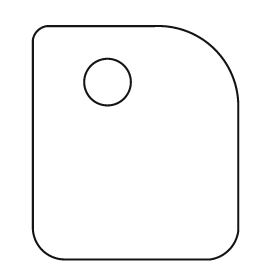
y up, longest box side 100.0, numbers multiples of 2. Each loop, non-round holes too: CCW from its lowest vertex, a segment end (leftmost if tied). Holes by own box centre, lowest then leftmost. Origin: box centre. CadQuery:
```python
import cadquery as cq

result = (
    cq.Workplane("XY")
    .moveTo(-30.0, -50.0)
    .lineTo(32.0, -50.0)
    .threePointArc((40.0, -46.0), (44.0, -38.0))
    .lineTo(44.0, 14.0)
    .threePointArc((34.0, 40.0), (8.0, 50.0))
    .lineTo(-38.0, 50.0)
    .threePointArc((-42.0, 48.0), (-44.0, 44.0))
    .lineTo(-44.0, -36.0)
    .threePointArc((-40.0, -46.0), (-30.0, -50.0))
    .close()
    .moveTo(-12.0, 26.0)
    .circle(10.0)
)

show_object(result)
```